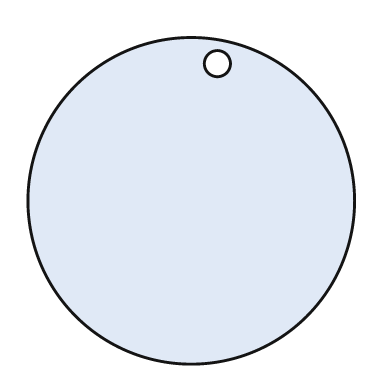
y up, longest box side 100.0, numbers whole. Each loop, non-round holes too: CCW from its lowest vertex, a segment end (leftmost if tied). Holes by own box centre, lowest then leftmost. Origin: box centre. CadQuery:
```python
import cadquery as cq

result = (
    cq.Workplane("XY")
    .moveTo(0.0, 0.0)
    .circle(50.0)
    .moveTo(8.0, 42.0)
    .circle(4.0)
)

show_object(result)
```